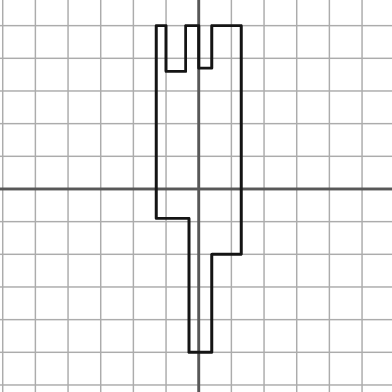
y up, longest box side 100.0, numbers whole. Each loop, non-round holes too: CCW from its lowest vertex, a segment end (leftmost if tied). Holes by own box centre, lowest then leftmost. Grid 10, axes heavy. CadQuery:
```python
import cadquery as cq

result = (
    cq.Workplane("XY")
    .moveTo(-3.0, -50.0)
    .lineTo(4.0, -50.0)
    .lineTo(4.0, -20.0)
    .lineTo(13.0, -20.0)
    .lineTo(13.0, 50.0)
    .lineTo(4.0, 50.0)
    .lineTo(4.0, 37.0)
    .lineTo(0.0, 37.0)
    .lineTo(0.0, 50.0)
    .lineTo(-4.0, 50.0)
    .lineTo(-4.0, 36.0)
    .lineTo(-10.0, 36.0)
    .lineTo(-10.0, 50.0)
    .lineTo(-13.0, 50.0)
    .lineTo(-13.0, -9.0)
    .lineTo(-3.0, -9.0)
    .close()
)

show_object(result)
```